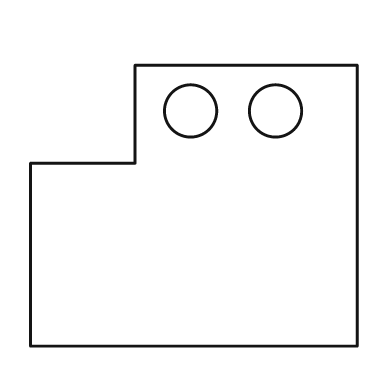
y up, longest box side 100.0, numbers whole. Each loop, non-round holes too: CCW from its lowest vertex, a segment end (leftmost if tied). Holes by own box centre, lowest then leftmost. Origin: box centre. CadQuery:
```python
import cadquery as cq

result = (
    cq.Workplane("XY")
    .moveTo(-50.0, -43.0)
    .lineTo(50.0, -43.0)
    .lineTo(50.0, 43.0)
    .lineTo(-18.0, 43.0)
    .lineTo(-18.0, 13.0)
    .lineTo(-50.0, 13.0)
    .close()
    .moveTo(-1.0, 29.0)
    .circle(8.0)
    .moveTo(25.0, 29.0)
    .circle(8.0)
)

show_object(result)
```